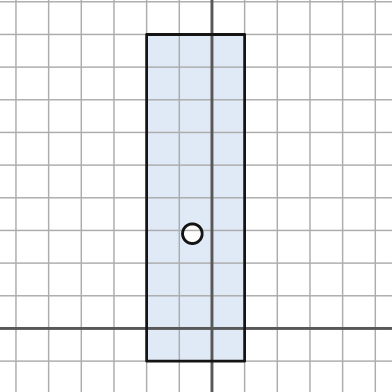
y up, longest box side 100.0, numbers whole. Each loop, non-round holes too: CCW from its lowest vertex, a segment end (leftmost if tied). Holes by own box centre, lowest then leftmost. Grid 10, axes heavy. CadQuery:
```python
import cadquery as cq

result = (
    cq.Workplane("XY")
    .moveTo(-20.0, -10.0)
    .lineTo(10.0, -10.0)
    .lineTo(10.0, 90.0)
    .lineTo(-20.0, 90.0)
    .close()
    .moveTo(-6.0, 29.0)
    .circle(3.0)
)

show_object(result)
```